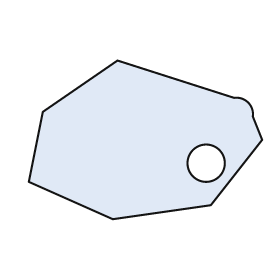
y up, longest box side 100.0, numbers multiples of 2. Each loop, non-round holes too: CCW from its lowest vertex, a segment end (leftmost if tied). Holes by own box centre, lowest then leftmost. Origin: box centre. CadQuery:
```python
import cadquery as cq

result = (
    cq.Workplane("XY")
    .moveTo(-14.0, -34.0)
    .lineTo(28.0, -28.0)
    .lineTo(50.0, 0.0)
    .lineTo(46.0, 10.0)
    .threePointArc((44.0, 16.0), (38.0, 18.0))
    .lineTo(-12.0, 34.0)
    .lineTo(-44.0, 12.0)
    .lineTo(-50.0, -18.0)
    .close()
    .moveTo(26.0, -10.0)
    .circle(8.0)
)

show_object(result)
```